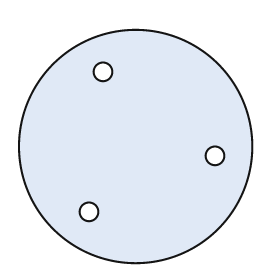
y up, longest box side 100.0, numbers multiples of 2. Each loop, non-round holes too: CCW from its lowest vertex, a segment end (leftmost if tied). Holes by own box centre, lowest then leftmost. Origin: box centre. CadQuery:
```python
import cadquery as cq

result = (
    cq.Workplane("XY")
    .moveTo(0.0, 0.0)
    .circle(50.0)
    .moveTo(-20.0, -28.0)
    .circle(4.0)
    .moveTo(34.0, -4.0)
    .circle(4.0)
    .moveTo(-14.0, 32.0)
    .circle(4.0)
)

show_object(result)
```